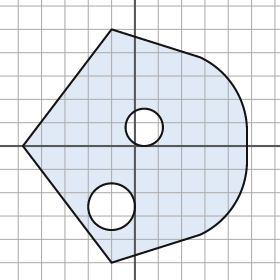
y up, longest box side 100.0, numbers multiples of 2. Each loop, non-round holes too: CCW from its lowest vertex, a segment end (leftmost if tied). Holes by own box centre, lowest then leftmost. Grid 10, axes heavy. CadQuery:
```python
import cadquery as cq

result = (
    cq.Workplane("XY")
    .moveTo(-10.0, -50.0)
    .lineTo(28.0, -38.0)
    .threePointArc((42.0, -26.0), (48.0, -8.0))
    .lineTo(48.0, 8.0)
    .threePointArc((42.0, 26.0), (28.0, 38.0))
    .lineTo(-10.0, 50.0)
    .lineTo(-48.0, 0.0)
    .close()
    .moveTo(-10.0, -26.0)
    .circle(10.0)
    .moveTo(4.0, 8.0)
    .circle(8.0)
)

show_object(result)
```